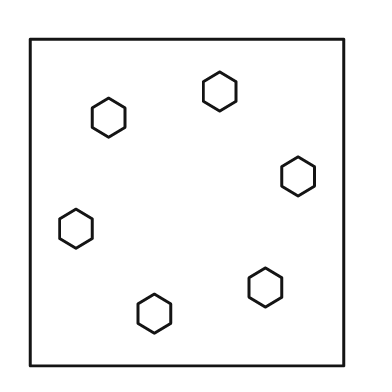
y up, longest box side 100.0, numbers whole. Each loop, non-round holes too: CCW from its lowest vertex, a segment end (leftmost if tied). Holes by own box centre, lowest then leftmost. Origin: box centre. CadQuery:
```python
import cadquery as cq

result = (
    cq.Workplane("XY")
    .moveTo(-48.0, -50.0)
    .lineTo(48.0, -50.0)
    .lineTo(48.0, 50.0)
    .lineTo(-48.0, 50.0)
    .close()
    .moveTo(-10.0, -40.0)
    .lineTo(-5.0, -37.0)
    .lineTo(-5.0, -31.0)
    .lineTo(-10.0, -28.0)
    .lineTo(-15.0, -31.0)
    .lineTo(-15.0, -37.0)
    .close()
    .moveTo(24.0, -32.0)
    .lineTo(29.0, -29.0)
    .lineTo(29.0, -23.0)
    .lineTo(24.0, -20.0)
    .lineTo(19.0, -23.0)
    .lineTo(19.0, -29.0)
    .close()
    .moveTo(-34.0, -14.0)
    .lineTo(-29.0, -11.0)
    .lineTo(-29.0, -5.0)
    .lineTo(-34.0, -2.0)
    .lineTo(-39.0, -5.0)
    .lineTo(-39.0, -11.0)
    .close()
    .moveTo(34.0, 2.0)
    .lineTo(39.0, 5.0)
    .lineTo(39.0, 11.0)
    .lineTo(34.0, 14.0)
    .lineTo(29.0, 11.0)
    .lineTo(29.0, 5.0)
    .close()
    .moveTo(-24.0, 20.0)
    .lineTo(-19.0, 23.0)
    .lineTo(-19.0, 29.0)
    .lineTo(-24.0, 32.0)
    .lineTo(-29.0, 29.0)
    .lineTo(-29.0, 23.0)
    .close()
    .moveTo(10.0, 28.0)
    .lineTo(15.0, 31.0)
    .lineTo(15.0, 37.0)
    .lineTo(10.0, 40.0)
    .lineTo(5.0, 37.0)
    .lineTo(5.0, 31.0)
    .close()
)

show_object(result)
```